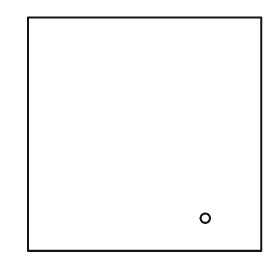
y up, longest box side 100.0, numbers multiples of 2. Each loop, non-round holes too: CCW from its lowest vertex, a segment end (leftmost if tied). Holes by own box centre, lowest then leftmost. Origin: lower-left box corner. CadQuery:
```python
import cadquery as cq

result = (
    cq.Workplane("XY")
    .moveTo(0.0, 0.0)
    .lineTo(100.0, 0.0)
    .lineTo(100.0, 100.0)
    .lineTo(0.0, 100.0)
    .close()
    .moveTo(76.0, 14.0)
    .circle(2.0)
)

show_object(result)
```